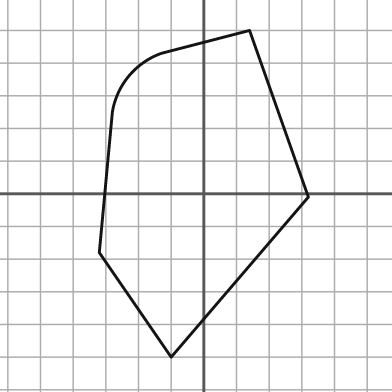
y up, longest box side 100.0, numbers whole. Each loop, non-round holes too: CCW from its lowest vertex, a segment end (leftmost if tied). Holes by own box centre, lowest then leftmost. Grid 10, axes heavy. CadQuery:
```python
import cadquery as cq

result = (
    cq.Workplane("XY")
    .moveTo(-10.0, -50.0)
    .lineTo(32.0, -1.0)
    .lineTo(14.0, 50.0)
    .lineTo(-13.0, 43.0)
    .threePointArc((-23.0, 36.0), (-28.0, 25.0))
    .lineTo(-32.0, -18.0)
    .close()
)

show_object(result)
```